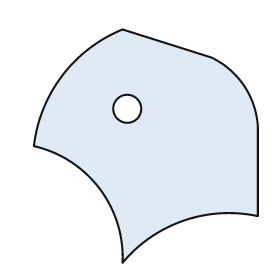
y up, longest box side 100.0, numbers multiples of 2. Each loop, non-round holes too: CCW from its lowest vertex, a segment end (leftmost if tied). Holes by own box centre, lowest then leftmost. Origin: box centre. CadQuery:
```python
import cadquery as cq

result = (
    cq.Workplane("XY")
    .moveTo(-10.0, -50.0)
    .threePointArc((16.0, -32.0), (48.0, -30.0))
    .lineTo(48.0, 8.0)
    .threePointArc((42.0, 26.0), (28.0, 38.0))
    .lineTo(-10.0, 50.0)
    .threePointArc((-36.0, 30.0), (-48.0, 0.0))
    .threePointArc((-20.0, -18.0), (-10.0, -50.0))
    .close()
    .moveTo(-8.0, 16.0)
    .circle(6.0)
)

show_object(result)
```